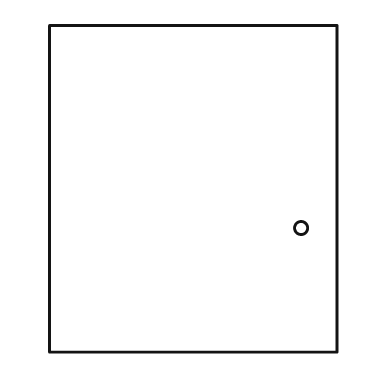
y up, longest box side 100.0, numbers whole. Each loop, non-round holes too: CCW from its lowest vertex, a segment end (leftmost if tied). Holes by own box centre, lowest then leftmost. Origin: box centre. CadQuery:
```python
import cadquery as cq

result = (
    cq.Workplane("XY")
    .moveTo(-44.0, -50.0)
    .lineTo(44.0, -50.0)
    .lineTo(44.0, 50.0)
    .lineTo(-44.0, 50.0)
    .close()
    .moveTo(33.0, -12.0)
    .circle(2.0)
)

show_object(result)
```